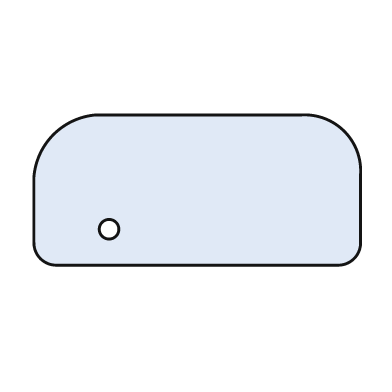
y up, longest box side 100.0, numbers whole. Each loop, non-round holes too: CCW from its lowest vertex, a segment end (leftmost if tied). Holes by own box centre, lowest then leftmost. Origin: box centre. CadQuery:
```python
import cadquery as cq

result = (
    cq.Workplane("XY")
    .moveTo(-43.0, -23.0)
    .lineTo(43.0, -23.0)
    .threePointArc((48.0, -21.0), (50.0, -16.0))
    .lineTo(50.0, 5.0)
    .threePointArc((45.0, 18.0), (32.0, 23.0))
    .lineTo(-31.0, 23.0)
    .threePointArc((-44.0, 17.0), (-50.0, 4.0))
    .lineTo(-50.0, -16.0)
    .threePointArc((-48.0, -21.0), (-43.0, -23.0))
    .close()
    .moveTo(-27.0, -12.0)
    .circle(3.0)
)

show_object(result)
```